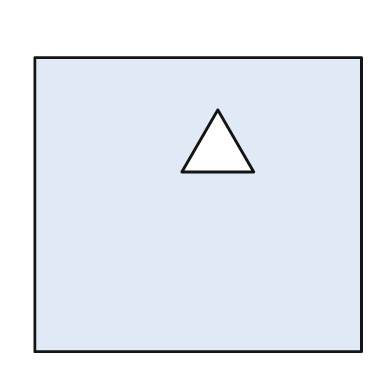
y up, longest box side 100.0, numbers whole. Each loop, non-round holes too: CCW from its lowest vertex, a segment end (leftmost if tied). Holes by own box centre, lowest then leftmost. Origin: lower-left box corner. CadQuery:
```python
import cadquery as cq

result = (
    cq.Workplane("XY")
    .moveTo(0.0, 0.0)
    .lineTo(100.0, 0.0)
    .lineTo(100.0, 90.0)
    .lineTo(0.0, 90.0)
    .close()
    .moveTo(45.0, 55.0)
    .lineTo(67.0, 55.0)
    .lineTo(56.0, 74.0)
    .close()
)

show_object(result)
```